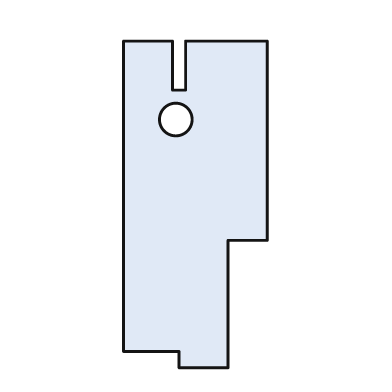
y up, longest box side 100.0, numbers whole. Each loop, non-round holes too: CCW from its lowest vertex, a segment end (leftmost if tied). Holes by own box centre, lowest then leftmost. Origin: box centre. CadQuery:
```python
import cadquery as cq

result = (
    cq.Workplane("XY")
    .moveTo(-5.0, -50.0)
    .lineTo(10.0, -50.0)
    .lineTo(10.0, -11.0)
    .lineTo(22.0, -11.0)
    .lineTo(22.0, 50.0)
    .lineTo(-3.0, 50.0)
    .lineTo(-3.0, 35.0)
    .lineTo(-7.0, 35.0)
    .lineTo(-7.0, 50.0)
    .lineTo(-22.0, 50.0)
    .lineTo(-22.0, -45.0)
    .lineTo(-5.0, -45.0)
    .close()
    .moveTo(-6.0, 26.0)
    .circle(5.0)
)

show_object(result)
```